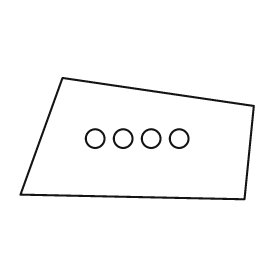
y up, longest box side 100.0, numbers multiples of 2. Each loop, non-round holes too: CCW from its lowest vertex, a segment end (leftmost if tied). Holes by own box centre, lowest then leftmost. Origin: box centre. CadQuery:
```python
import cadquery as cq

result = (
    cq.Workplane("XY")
    .moveTo(46.0, -26.0)
    .lineTo(50.0, 14.0)
    .lineTo(-32.0, 26.0)
    .lineTo(-50.0, -24.0)
    .close()
    .moveTo(-18.0, 0.0)
    .circle(4.0)
    .moveTo(-6.0, 0.0)
    .circle(4.0)
    .moveTo(6.0, 0.0)
    .circle(4.0)
    .moveTo(18.0, 0.0)
    .circle(4.0)
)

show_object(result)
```